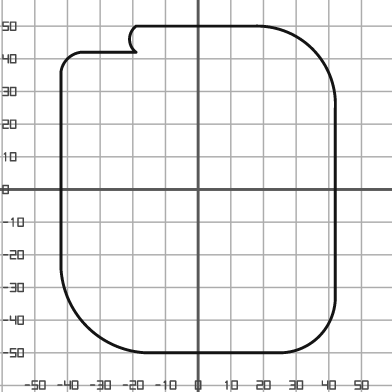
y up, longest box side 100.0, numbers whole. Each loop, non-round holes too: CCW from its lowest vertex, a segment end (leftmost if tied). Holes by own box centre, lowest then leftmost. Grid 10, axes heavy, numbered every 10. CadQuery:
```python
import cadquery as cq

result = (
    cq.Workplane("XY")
    .moveTo(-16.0, -50.0)
    .lineTo(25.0, -50.0)
    .threePointArc((37.0, -45.0), (42.0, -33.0))
    .lineTo(42.0, 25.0)
    .threePointArc((35.0, 43.0), (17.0, 50.0))
    .lineTo(-19.0, 50.0)
    .threePointArc((-21.0, 46.0), (-19.0, 42.0))
    .lineTo(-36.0, 42.0)
    .threePointArc((-40.0, 40.0), (-42.0, 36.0))
    .lineTo(-42.0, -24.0)
    .threePointArc((-34.0, -42.0), (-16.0, -50.0))
    .close()
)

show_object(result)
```